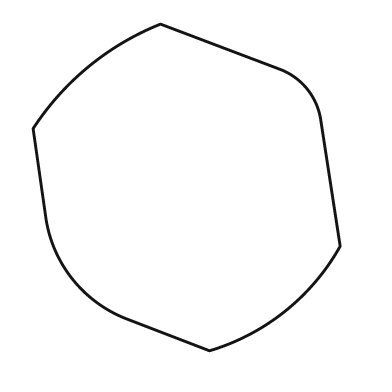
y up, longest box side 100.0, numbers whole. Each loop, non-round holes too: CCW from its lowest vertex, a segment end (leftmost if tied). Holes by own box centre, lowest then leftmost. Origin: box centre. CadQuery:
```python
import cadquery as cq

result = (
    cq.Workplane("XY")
    .moveTo(7.0, -50.0)
    .threePointArc((30.0, -38.0), (47.0, -18.0))
    .lineTo(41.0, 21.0)
    .threePointArc((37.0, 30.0), (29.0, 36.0))
    .lineTo(-8.0, 50.0)
    .threePointArc((-30.0, 37.0), (-47.0, 18.0))
    .lineTo(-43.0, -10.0)
    .threePointArc((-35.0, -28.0), (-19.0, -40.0))
    .close()
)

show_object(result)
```